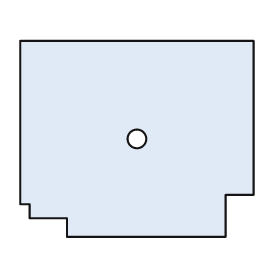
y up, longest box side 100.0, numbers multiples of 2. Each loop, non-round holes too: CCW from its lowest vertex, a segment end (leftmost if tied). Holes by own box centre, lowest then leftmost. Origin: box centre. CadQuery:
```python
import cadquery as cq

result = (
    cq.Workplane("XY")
    .moveTo(-30.0, -42.0)
    .lineTo(38.0, -42.0)
    .lineTo(38.0, -24.0)
    .lineTo(50.0, -24.0)
    .lineTo(50.0, 42.0)
    .lineTo(-50.0, 42.0)
    .lineTo(-50.0, -28.0)
    .lineTo(-46.0, -28.0)
    .lineTo(-46.0, -34.0)
    .lineTo(-30.0, -34.0)
    .close()
    .moveTo(0.0, 0.0)
    .circle(4.0)
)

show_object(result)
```